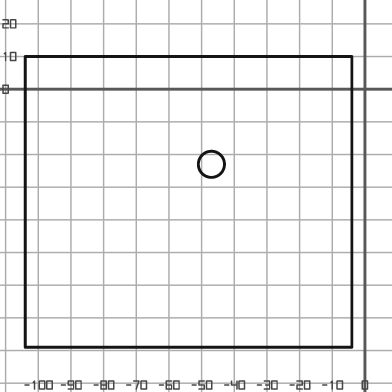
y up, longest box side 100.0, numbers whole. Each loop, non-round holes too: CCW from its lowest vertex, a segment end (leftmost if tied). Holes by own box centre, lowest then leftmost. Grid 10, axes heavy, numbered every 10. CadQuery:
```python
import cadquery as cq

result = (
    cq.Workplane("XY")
    .moveTo(-104.0, -79.0)
    .lineTo(-4.0, -79.0)
    .lineTo(-4.0, 10.0)
    .lineTo(-104.0, 10.0)
    .close()
    .moveTo(-47.0, -23.0)
    .circle(4.0)
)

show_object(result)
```